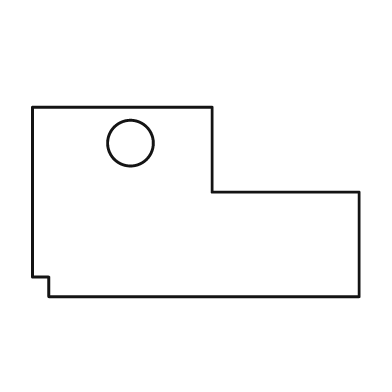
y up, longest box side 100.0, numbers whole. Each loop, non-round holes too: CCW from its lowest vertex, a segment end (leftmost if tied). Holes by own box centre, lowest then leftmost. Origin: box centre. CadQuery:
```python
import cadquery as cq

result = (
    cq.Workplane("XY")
    .moveTo(-45.0, -29.0)
    .lineTo(50.0, -29.0)
    .lineTo(50.0, 3.0)
    .lineTo(5.0, 3.0)
    .lineTo(5.0, 29.0)
    .lineTo(-50.0, 29.0)
    .lineTo(-50.0, -23.0)
    .lineTo(-45.0, -23.0)
    .close()
    .moveTo(-20.0, 18.0)
    .circle(7.0)
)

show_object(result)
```